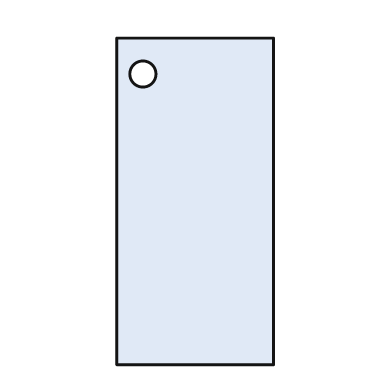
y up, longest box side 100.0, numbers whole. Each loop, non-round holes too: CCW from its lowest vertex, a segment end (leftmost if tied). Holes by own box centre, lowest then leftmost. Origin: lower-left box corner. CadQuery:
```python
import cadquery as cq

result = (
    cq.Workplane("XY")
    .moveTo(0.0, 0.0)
    .lineTo(48.0, 0.0)
    .lineTo(48.0, 100.0)
    .lineTo(0.0, 100.0)
    .close()
    .moveTo(8.0, 89.0)
    .circle(4.0)
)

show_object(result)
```